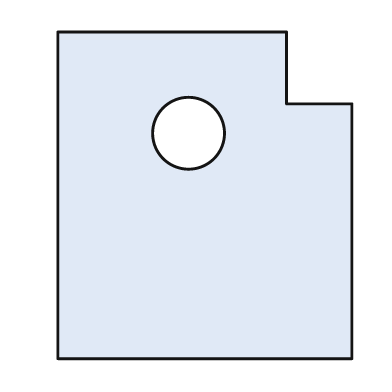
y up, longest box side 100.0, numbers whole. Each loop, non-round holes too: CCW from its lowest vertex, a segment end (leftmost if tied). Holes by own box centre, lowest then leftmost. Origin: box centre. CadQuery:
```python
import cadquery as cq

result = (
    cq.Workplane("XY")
    .moveTo(-45.0, -50.0)
    .lineTo(45.0, -50.0)
    .lineTo(45.0, 28.0)
    .lineTo(25.0, 28.0)
    .lineTo(25.0, 50.0)
    .lineTo(-45.0, 50.0)
    .close()
    .moveTo(-5.0, 19.0)
    .circle(11.0)
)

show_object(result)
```